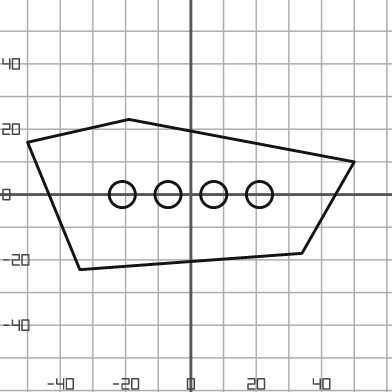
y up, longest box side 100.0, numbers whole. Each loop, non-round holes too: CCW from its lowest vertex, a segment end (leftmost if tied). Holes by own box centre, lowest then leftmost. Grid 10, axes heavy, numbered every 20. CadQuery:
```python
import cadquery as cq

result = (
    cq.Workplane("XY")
    .moveTo(-34.0, -23.0)
    .lineTo(34.0, -18.0)
    .lineTo(50.0, 10.0)
    .lineTo(-19.0, 23.0)
    .lineTo(-50.0, 16.0)
    .close()
    .moveTo(-21.0, 0.0)
    .circle(4.0)
    .moveTo(-7.0, 0.0)
    .circle(4.0)
    .moveTo(7.0, 0.0)
    .circle(4.0)
    .moveTo(21.0, 0.0)
    .circle(4.0)
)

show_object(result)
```